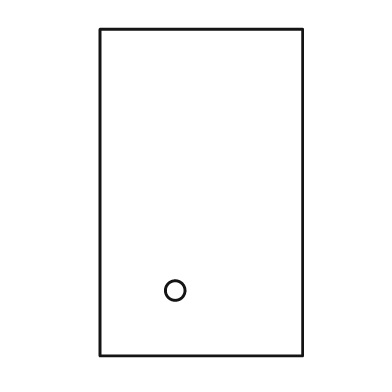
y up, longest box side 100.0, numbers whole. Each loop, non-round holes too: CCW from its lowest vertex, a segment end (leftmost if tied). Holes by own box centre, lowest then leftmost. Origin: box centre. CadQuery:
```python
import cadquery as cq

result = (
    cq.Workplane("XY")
    .moveTo(-31.0, -50.0)
    .lineTo(31.0, -50.0)
    .lineTo(31.0, 50.0)
    .lineTo(-31.0, 50.0)
    .close()
    .moveTo(-8.0, -30.0)
    .circle(3.0)
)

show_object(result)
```